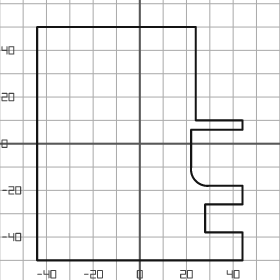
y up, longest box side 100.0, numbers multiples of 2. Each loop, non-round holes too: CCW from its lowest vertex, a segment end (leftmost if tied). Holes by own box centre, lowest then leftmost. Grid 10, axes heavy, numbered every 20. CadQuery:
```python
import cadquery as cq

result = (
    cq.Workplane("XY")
    .moveTo(-44.0, -50.0)
    .lineTo(44.0, -50.0)
    .lineTo(44.0, -38.0)
    .lineTo(28.0, -38.0)
    .lineTo(28.0, -26.0)
    .lineTo(44.0, -26.0)
    .lineTo(44.0, -18.0)
    .lineTo(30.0, -18.0)
    .threePointArc((24.0, -16.0), (22.0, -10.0))
    .lineTo(22.0, 6.0)
    .lineTo(44.0, 6.0)
    .lineTo(44.0, 10.0)
    .lineTo(24.0, 10.0)
    .lineTo(24.0, 50.0)
    .lineTo(-44.0, 50.0)
    .close()
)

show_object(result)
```